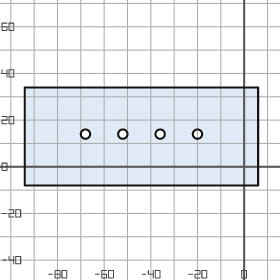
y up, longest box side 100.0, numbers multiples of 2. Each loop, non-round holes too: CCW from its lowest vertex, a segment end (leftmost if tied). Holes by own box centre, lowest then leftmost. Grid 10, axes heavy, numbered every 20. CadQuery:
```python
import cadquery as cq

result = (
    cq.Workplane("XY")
    .moveTo(-94.0, -8.0)
    .lineTo(6.0, -8.0)
    .lineTo(6.0, 34.0)
    .lineTo(-94.0, 34.0)
    .close()
    .moveTo(-68.0, 14.0)
    .circle(2.0)
    .moveTo(-52.0, 14.0)
    .circle(2.0)
    .moveTo(-36.0, 14.0)
    .circle(2.0)
    .moveTo(-20.0, 14.0)
    .circle(2.0)
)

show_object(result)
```